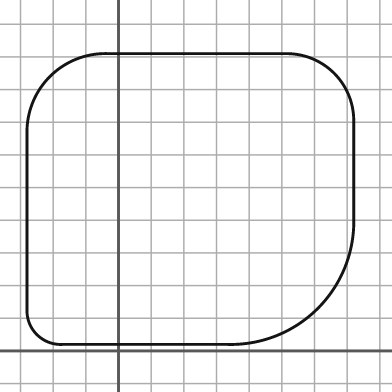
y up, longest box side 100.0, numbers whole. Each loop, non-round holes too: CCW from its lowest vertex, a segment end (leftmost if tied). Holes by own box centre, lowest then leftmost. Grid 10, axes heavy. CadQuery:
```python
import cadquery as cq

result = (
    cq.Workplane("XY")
    .moveTo(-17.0, 2.0)
    .lineTo(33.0, 2.0)
    .threePointArc((61.0, 13.0), (72.0, 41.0))
    .lineTo(72.0, 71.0)
    .threePointArc((66.0, 85.0), (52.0, 91.0))
    .lineTo(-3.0, 91.0)
    .threePointArc((-21.0, 84.0), (-28.0, 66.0))
    .lineTo(-28.0, 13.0)
    .threePointArc((-25.0, 5.0), (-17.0, 2.0))
    .close()
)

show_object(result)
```